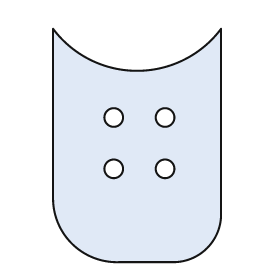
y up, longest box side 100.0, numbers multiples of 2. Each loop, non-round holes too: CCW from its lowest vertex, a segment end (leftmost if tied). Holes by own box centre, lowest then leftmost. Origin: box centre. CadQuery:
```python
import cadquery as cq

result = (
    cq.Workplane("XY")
    .moveTo(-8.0, -50.0)
    .lineTo(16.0, -50.0)
    .threePointArc((30.0, -44.0), (36.0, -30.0))
    .lineTo(36.0, 50.0)
    .threePointArc((0.0, 32.0), (-36.0, 50.0))
    .lineTo(-36.0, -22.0)
    .threePointArc((-28.0, -42.0), (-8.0, -50.0))
    .close()
    .moveTo(-10.0, -10.0)
    .circle(4.0)
    .moveTo(12.0, -10.0)
    .circle(4.0)
    .moveTo(-10.0, 12.0)
    .circle(4.0)
    .moveTo(12.0, 12.0)
    .circle(4.0)
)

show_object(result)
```